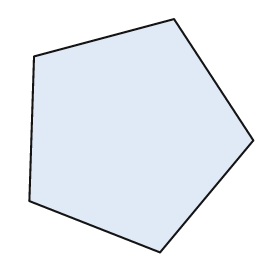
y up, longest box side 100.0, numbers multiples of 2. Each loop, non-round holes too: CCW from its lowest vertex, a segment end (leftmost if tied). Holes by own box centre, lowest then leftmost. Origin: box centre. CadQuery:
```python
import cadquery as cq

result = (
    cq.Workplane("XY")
    .moveTo(8.0, -50.0)
    .lineTo(48.0, -2.0)
    .lineTo(14.0, 50.0)
    .lineTo(-46.0, 34.0)
    .lineTo(-48.0, -28.0)
    .close()
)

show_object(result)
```